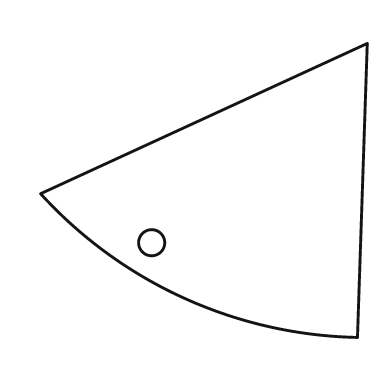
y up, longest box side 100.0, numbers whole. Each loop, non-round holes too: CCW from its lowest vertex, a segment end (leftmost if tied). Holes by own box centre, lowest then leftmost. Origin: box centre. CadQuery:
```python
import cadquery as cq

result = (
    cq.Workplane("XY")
    .moveTo(47.0, -45.0)
    .lineTo(50.0, 45.0)
    .lineTo(-50.0, -1.0)
    .threePointArc((-6.0, -33.0), (47.0, -45.0))
    .close()
    .moveTo(-16.0, -16.0)
    .circle(4.0)
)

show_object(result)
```